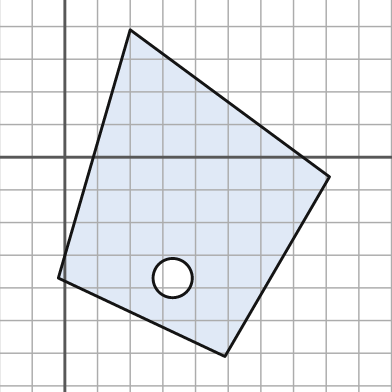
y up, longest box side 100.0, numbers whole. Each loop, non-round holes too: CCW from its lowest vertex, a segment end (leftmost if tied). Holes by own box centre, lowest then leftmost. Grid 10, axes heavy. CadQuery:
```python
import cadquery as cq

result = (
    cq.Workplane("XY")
    .moveTo(49.0, -61.0)
    .lineTo(81.0, -6.0)
    .lineTo(20.0, 39.0)
    .lineTo(-2.0, -37.0)
    .close()
    .moveTo(33.0, -37.0)
    .circle(6.0)
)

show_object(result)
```